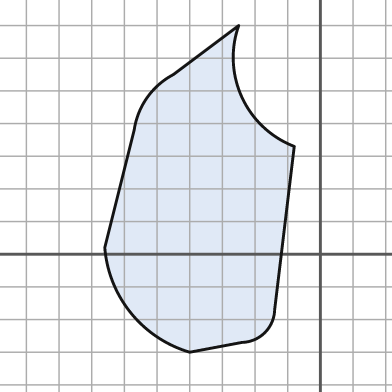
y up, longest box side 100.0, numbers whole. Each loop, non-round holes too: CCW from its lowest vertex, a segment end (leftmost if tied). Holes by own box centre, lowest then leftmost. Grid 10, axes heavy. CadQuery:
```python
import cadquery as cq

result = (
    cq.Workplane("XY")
    .moveTo(-40.0, -30.0)
    .lineTo(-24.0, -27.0)
    .threePointArc((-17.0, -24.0), (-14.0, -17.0))
    .lineTo(-8.0, 33.0)
    .threePointArc((-24.0, 48.0), (-25.0, 70.0))
    .lineTo(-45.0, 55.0)
    .threePointArc((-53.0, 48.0), (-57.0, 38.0))
    .lineTo(-66.0, 2.0)
    .threePointArc((-58.0, -18.0), (-40.0, -30.0))
    .close()
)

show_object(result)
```